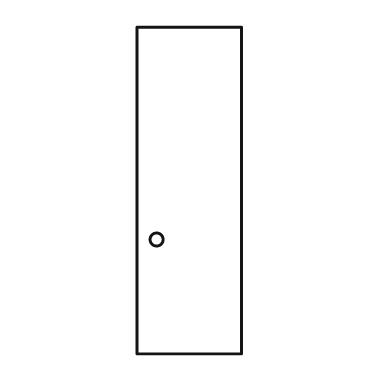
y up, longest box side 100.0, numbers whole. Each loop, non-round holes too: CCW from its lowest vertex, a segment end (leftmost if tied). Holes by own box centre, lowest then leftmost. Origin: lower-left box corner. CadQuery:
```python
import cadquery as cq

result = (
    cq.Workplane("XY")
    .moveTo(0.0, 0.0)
    .lineTo(32.0, 0.0)
    .lineTo(32.0, 100.0)
    .lineTo(0.0, 100.0)
    .close()
    .moveTo(6.0, 35.0)
    .circle(2.0)
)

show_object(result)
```